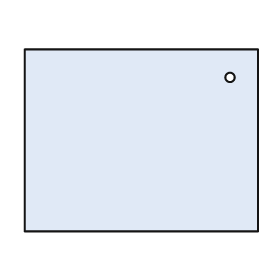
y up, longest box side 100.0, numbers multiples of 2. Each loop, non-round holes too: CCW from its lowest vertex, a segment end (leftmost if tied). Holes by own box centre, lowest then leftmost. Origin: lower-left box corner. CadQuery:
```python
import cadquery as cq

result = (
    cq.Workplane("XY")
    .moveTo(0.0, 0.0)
    .lineTo(100.0, 0.0)
    .lineTo(100.0, 78.0)
    .lineTo(0.0, 78.0)
    .close()
    .moveTo(88.0, 66.0)
    .circle(2.0)
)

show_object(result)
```